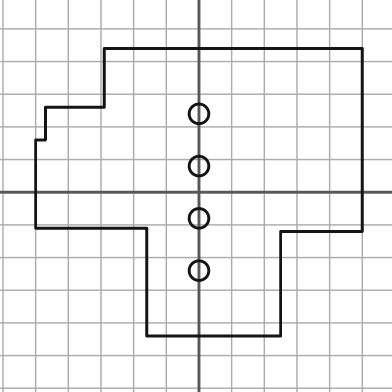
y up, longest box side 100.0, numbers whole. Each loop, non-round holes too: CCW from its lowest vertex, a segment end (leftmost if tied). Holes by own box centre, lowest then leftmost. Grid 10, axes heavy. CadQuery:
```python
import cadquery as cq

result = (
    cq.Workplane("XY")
    .moveTo(-16.0, -44.0)
    .lineTo(25.0, -44.0)
    .lineTo(25.0, -12.0)
    .lineTo(50.0, -12.0)
    .lineTo(50.0, 44.0)
    .lineTo(-29.0, 44.0)
    .lineTo(-29.0, 26.0)
    .lineTo(-47.0, 26.0)
    .lineTo(-47.0, 16.0)
    .lineTo(-50.0, 16.0)
    .lineTo(-50.0, -11.0)
    .lineTo(-16.0, -11.0)
    .close()
    .moveTo(0.0, -24.0)
    .circle(3.0)
    .moveTo(0.0, -8.0)
    .circle(3.0)
    .moveTo(0.0, 8.0)
    .circle(3.0)
    .moveTo(0.0, 24.0)
    .circle(3.0)
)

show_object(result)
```